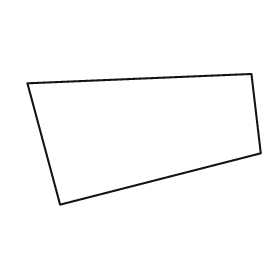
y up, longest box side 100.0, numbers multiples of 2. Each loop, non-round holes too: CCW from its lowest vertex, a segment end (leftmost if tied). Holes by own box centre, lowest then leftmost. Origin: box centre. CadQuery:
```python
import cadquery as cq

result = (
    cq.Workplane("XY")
    .moveTo(-36.0, -28.0)
    .lineTo(50.0, -6.0)
    .lineTo(46.0, 28.0)
    .lineTo(-50.0, 24.0)
    .close()
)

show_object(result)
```